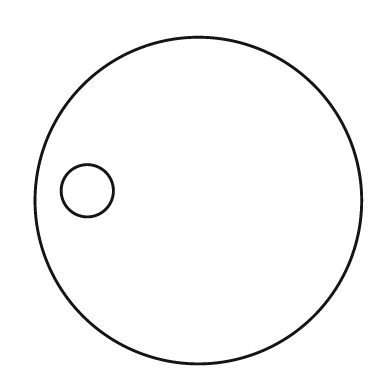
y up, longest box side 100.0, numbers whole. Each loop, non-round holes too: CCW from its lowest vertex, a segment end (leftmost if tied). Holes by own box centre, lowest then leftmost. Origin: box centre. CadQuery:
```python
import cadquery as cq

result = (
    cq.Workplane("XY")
    .moveTo(0.0, 0.0)
    .circle(50.0)
    .moveTo(-34.0, 3.0)
    .circle(8.0)
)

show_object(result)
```